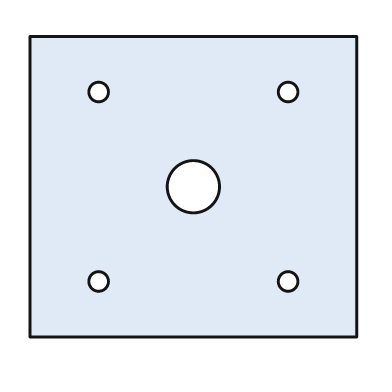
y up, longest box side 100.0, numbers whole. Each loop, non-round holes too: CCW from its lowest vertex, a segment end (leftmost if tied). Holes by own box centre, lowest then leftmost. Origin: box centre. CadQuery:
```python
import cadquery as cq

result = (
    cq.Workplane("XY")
    .moveTo(-50.0, -46.0)
    .lineTo(50.0, -46.0)
    .lineTo(50.0, 46.0)
    .lineTo(-50.0, 46.0)
    .close()
    .moveTo(-29.0, -29.0)
    .circle(3.0)
    .moveTo(29.0, -29.0)
    .circle(3.0)
    .moveTo(0.0, 0.0)
    .circle(8.0)
    .moveTo(-29.0, 29.0)
    .circle(3.0)
    .moveTo(29.0, 29.0)
    .circle(3.0)
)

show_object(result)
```